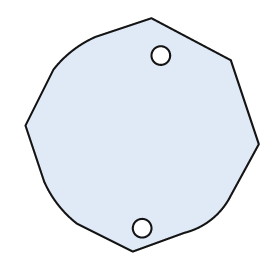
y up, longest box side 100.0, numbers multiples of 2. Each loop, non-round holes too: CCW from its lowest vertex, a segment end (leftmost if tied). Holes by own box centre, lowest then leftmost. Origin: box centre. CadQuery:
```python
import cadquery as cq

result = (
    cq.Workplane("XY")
    .moveTo(-4.0, -50.0)
    .lineTo(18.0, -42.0)
    .threePointArc((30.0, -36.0), (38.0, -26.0))
    .lineTo(50.0, -4.0)
    .lineTo(38.0, 32.0)
    .lineTo(4.0, 50.0)
    .lineTo(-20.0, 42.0)
    .threePointArc((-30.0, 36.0), (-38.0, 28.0))
    .lineTo(-50.0, 4.0)
    .lineTo(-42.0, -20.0)
    .threePointArc((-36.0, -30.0), (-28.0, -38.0))
    .close()
    .moveTo(0.0, -40.0)
    .circle(4.0)
    .moveTo(8.0, 34.0)
    .circle(4.0)
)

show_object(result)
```